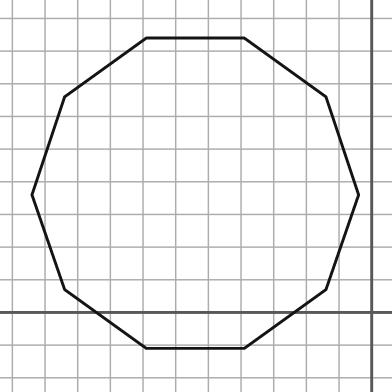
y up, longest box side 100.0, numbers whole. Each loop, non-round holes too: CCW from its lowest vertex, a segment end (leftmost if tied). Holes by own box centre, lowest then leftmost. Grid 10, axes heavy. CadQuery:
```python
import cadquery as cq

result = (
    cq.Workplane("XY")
    .moveTo(-69.0, -11.0)
    .lineTo(-39.0, -11.0)
    .lineTo(-14.0, 7.0)
    .lineTo(-4.0, 36.0)
    .lineTo(-14.0, 66.0)
    .lineTo(-39.0, 84.0)
    .lineTo(-69.0, 84.0)
    .lineTo(-94.0, 66.0)
    .lineTo(-104.0, 36.0)
    .lineTo(-94.0, 7.0)
    .close()
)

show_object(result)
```